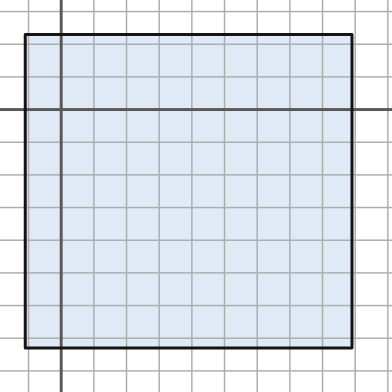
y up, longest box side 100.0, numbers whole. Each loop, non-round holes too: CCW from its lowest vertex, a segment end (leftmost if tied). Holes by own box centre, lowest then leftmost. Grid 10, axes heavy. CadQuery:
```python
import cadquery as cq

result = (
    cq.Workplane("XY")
    .moveTo(-11.0, -73.0)
    .lineTo(89.0, -73.0)
    .lineTo(89.0, 23.0)
    .lineTo(-11.0, 23.0)
    .close()
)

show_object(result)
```